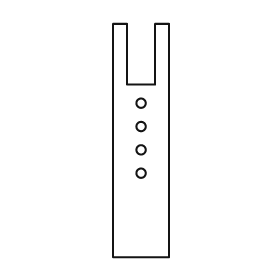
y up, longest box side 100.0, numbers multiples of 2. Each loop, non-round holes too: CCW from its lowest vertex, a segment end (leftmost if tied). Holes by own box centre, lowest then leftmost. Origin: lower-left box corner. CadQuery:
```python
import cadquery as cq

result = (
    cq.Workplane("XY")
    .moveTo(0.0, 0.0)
    .lineTo(24.0, 0.0)
    .lineTo(24.0, 100.0)
    .lineTo(18.0, 100.0)
    .lineTo(18.0, 74.0)
    .lineTo(6.0, 74.0)
    .lineTo(6.0, 100.0)
    .lineTo(0.0, 100.0)
    .close()
    .moveTo(12.0, 36.0)
    .circle(2.0)
    .moveTo(12.0, 46.0)
    .circle(2.0)
    .moveTo(12.0, 56.0)
    .circle(2.0)
    .moveTo(12.0, 66.0)
    .circle(2.0)
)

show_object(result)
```